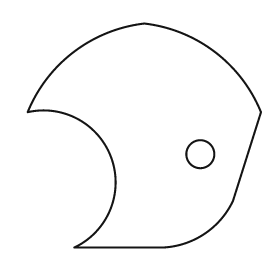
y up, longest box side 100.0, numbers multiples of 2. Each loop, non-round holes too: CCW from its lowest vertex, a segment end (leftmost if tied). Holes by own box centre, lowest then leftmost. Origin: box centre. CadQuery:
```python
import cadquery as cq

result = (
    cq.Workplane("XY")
    .moveTo(-30.0, -48.0)
    .lineTo(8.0, -48.0)
    .threePointArc((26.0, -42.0), (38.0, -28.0))
    .lineTo(50.0, 10.0)
    .threePointArc((30.0, 36.0), (0.0, 48.0))
    .threePointArc((-30.0, 36.0), (-50.0, 10.0))
    .threePointArc((-14.0, -10.0), (-30.0, -48.0))
    .close()
    .moveTo(24.0, -8.0)
    .circle(6.0)
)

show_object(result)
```